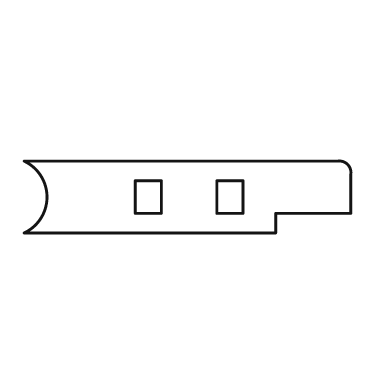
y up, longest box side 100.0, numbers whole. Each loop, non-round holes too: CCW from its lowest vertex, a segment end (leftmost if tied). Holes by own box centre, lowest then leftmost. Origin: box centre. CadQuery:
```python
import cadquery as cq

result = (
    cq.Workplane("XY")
    .moveTo(-50.0, -11.0)
    .lineTo(27.0, -11.0)
    .lineTo(27.0, -5.0)
    .lineTo(50.0, -5.0)
    .lineTo(50.0, 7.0)
    .threePointArc((49.0, 10.0), (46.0, 11.0))
    .lineTo(-50.0, 11.0)
    .threePointArc((-43.0, 0.0), (-50.0, -11.0))
    .close()
    .moveTo(-16.0, -5.0)
    .lineTo(-8.0, -5.0)
    .lineTo(-8.0, 5.0)
    .lineTo(-16.0, 5.0)
    .close()
    .moveTo(9.0, -5.0)
    .lineTo(17.0, -5.0)
    .lineTo(17.0, 5.0)
    .lineTo(9.0, 5.0)
    .close()
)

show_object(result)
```